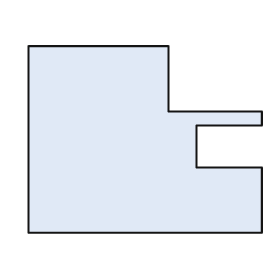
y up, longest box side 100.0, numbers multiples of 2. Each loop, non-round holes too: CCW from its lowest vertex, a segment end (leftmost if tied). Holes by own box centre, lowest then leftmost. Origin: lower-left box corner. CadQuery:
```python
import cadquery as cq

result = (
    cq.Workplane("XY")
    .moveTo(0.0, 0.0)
    .lineTo(100.0, 0.0)
    .lineTo(100.0, 28.0)
    .lineTo(72.0, 28.0)
    .lineTo(72.0, 46.0)
    .lineTo(100.0, 46.0)
    .lineTo(100.0, 52.0)
    .lineTo(60.0, 52.0)
    .lineTo(60.0, 80.0)
    .lineTo(0.0, 80.0)
    .close()
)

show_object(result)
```